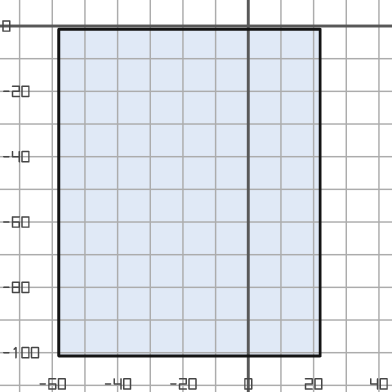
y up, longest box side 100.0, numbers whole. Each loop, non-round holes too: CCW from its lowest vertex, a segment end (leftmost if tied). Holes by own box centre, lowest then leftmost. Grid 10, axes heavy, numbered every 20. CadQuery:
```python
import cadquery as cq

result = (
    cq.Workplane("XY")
    .moveTo(-58.0, -101.0)
    .lineTo(22.0, -101.0)
    .lineTo(22.0, -1.0)
    .lineTo(-58.0, -1.0)
    .close()
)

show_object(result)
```